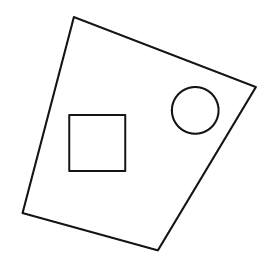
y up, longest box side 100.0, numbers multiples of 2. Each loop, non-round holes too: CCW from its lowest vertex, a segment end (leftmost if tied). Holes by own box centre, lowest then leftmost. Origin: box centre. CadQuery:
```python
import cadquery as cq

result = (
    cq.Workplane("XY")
    .moveTo(8.0, -50.0)
    .lineTo(50.0, 20.0)
    .lineTo(-28.0, 50.0)
    .lineTo(-50.0, -34.0)
    .close()
    .moveTo(-30.0, -16.0)
    .lineTo(-6.0, -16.0)
    .lineTo(-6.0, 8.0)
    .lineTo(-30.0, 8.0)
    .close()
    .moveTo(24.0, 10.0)
    .circle(10.0)
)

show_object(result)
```